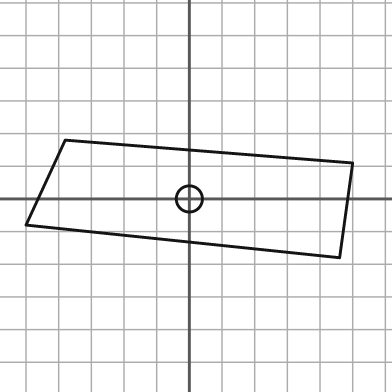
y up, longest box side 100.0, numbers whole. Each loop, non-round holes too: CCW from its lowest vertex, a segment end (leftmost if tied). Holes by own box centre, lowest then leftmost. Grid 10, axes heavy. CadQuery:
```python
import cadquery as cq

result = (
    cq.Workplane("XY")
    .moveTo(46.0, -18.0)
    .lineTo(50.0, 11.0)
    .lineTo(-38.0, 18.0)
    .lineTo(-50.0, -8.0)
    .close()
    .moveTo(0.0, 0.0)
    .circle(4.0)
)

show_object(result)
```